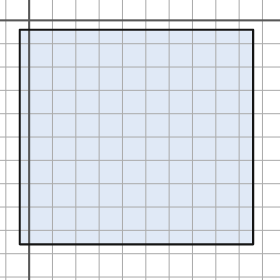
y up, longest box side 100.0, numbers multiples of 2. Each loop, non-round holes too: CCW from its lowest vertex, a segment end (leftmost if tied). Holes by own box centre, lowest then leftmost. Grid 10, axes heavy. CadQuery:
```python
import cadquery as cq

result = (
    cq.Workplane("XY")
    .moveTo(-4.0, -96.0)
    .lineTo(96.0, -96.0)
    .lineTo(96.0, -4.0)
    .lineTo(-4.0, -4.0)
    .close()
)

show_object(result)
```